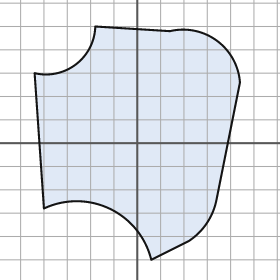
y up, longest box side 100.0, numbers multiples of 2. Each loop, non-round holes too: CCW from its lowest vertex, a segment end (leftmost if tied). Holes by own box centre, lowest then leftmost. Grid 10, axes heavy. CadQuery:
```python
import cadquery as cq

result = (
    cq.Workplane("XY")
    .moveTo(6.0, -50.0)
    .lineTo(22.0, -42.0)
    .threePointArc((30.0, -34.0), (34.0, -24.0))
    .lineTo(44.0, 26.0)
    .threePointArc((34.0, 44.0), (14.0, 48.0))
    .lineTo(-18.0, 50.0)
    .threePointArc((-26.0, 34.0), (-44.0, 30.0))
    .lineTo(-40.0, -28.0)
    .threePointArc((-12.0, -28.0), (6.0, -50.0))
    .close()
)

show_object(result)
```